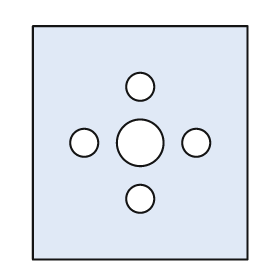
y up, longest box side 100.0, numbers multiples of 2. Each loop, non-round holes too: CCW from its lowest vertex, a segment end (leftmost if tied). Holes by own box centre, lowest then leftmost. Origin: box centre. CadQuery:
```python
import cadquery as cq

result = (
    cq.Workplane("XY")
    .moveTo(-46.0, -50.0)
    .lineTo(46.0, -50.0)
    .lineTo(46.0, 50.0)
    .lineTo(-46.0, 50.0)
    .close()
    .moveTo(0.0, -24.0)
    .circle(6.0)
    .moveTo(-24.0, 0.0)
    .circle(6.0)
    .moveTo(0.0, 0.0)
    .circle(10.0)
    .moveTo(24.0, 0.0)
    .circle(6.0)
    .moveTo(0.0, 24.0)
    .circle(6.0)
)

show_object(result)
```